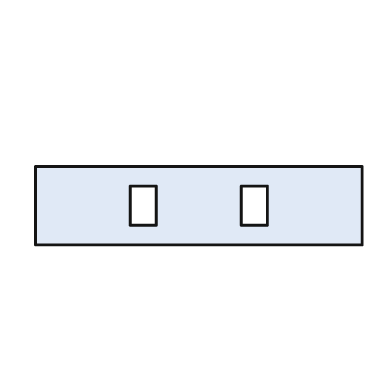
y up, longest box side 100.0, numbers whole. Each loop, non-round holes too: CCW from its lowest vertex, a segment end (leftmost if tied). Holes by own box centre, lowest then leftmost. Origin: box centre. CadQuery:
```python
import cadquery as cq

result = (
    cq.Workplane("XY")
    .moveTo(-50.0, -12.0)
    .lineTo(50.0, -12.0)
    .lineTo(50.0, 12.0)
    .lineTo(-50.0, 12.0)
    .close()
    .moveTo(-21.0, -6.0)
    .lineTo(-13.0, -6.0)
    .lineTo(-13.0, 6.0)
    .lineTo(-21.0, 6.0)
    .close()
    .moveTo(13.0, -6.0)
    .lineTo(21.0, -6.0)
    .lineTo(21.0, 6.0)
    .lineTo(13.0, 6.0)
    .close()
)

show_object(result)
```